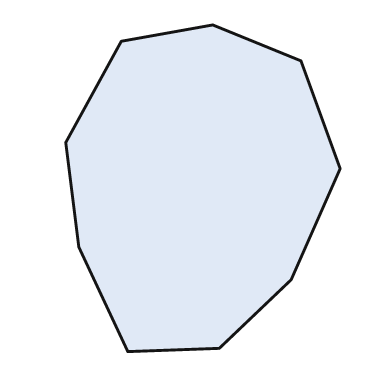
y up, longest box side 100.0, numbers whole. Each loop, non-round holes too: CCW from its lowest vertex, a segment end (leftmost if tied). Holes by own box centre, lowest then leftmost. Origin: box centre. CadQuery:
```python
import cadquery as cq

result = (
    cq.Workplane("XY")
    .moveTo(-23.0, -50.0)
    .lineTo(5.0, -49.0)
    .lineTo(27.0, -28.0)
    .lineTo(42.0, 6.0)
    .lineTo(30.0, 39.0)
    .lineTo(3.0, 50.0)
    .lineTo(-25.0, 45.0)
    .lineTo(-42.0, 14.0)
    .lineTo(-38.0, -18.0)
    .close()
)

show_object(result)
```